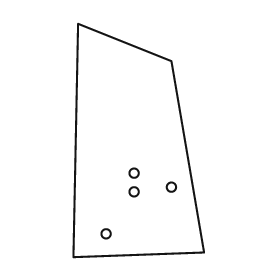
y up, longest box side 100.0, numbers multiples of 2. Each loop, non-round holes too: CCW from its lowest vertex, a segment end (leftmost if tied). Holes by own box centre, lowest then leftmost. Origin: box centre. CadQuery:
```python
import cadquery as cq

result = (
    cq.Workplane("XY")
    .moveTo(-28.0, -50.0)
    .lineTo(28.0, -48.0)
    .lineTo(14.0, 34.0)
    .lineTo(-26.0, 50.0)
    .close()
    .moveTo(-14.0, -40.0)
    .circle(2.0)
    .moveTo(-2.0, -22.0)
    .circle(2.0)
    .moveTo(14.0, -20.0)
    .circle(2.0)
    .moveTo(-2.0, -14.0)
    .circle(2.0)
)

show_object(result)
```